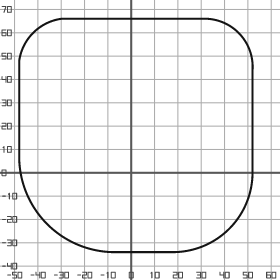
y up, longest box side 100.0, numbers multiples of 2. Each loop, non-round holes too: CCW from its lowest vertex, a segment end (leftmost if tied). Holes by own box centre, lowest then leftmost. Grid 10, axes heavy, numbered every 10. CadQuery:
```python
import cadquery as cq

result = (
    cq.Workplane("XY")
    .moveTo(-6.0, -34.0)
    .lineTo(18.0, -34.0)
    .threePointArc((42.0, -24.0), (52.0, 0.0))
    .lineTo(52.0, 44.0)
    .threePointArc((46.0, 60.0), (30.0, 66.0))
    .lineTo(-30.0, 66.0)
    .threePointArc((-42.0, 60.0), (-48.0, 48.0))
    .lineTo(-48.0, 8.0)
    .threePointArc((-36.0, -22.0), (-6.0, -34.0))
    .close()
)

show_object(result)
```